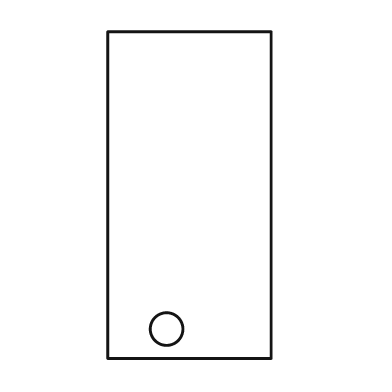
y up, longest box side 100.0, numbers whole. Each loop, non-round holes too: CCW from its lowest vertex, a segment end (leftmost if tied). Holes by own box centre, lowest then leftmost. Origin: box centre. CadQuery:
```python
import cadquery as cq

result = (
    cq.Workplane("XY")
    .moveTo(-25.0, -50.0)
    .lineTo(25.0, -50.0)
    .lineTo(25.0, 50.0)
    .lineTo(-25.0, 50.0)
    .close()
    .moveTo(-7.0, -41.0)
    .circle(5.0)
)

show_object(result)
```